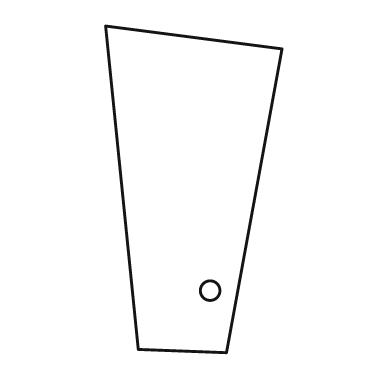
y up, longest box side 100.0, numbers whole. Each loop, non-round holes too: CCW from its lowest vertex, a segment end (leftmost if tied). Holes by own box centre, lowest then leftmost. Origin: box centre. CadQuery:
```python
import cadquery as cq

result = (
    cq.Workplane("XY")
    .moveTo(10.0, -50.0)
    .lineTo(27.0, 43.0)
    .lineTo(-27.0, 50.0)
    .lineTo(-17.0, -49.0)
    .close()
    .moveTo(5.0, -31.0)
    .circle(3.0)
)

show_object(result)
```